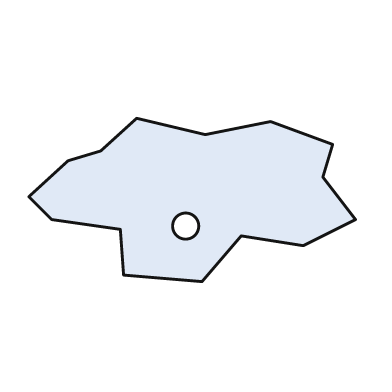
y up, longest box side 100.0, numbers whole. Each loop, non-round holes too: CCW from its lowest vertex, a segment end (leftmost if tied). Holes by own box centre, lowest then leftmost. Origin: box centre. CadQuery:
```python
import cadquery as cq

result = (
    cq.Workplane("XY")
    .moveTo(3.0, -25.0)
    .lineTo(15.0, -11.0)
    .lineTo(34.0, -14.0)
    .lineTo(50.0, -6.0)
    .lineTo(40.0, 7.0)
    .lineTo(43.0, 17.0)
    .lineTo(24.0, 24.0)
    .lineTo(4.0, 20.0)
    .lineTo(-17.0, 25.0)
    .lineTo(-28.0, 15.0)
    .lineTo(-38.0, 12.0)
    .lineTo(-50.0, 1.0)
    .lineTo(-43.0, -6.0)
    .lineTo(-22.0, -9.0)
    .lineTo(-21.0, -23.0)
    .close()
    .moveTo(-2.0, -8.0)
    .circle(4.0)
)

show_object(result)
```